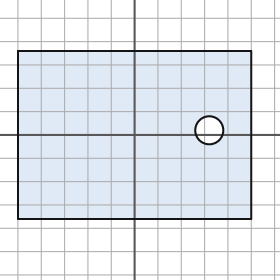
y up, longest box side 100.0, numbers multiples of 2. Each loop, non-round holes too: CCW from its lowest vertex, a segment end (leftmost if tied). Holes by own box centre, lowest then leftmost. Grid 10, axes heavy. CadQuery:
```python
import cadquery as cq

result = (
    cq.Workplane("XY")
    .moveTo(-50.0, -36.0)
    .lineTo(50.0, -36.0)
    .lineTo(50.0, 36.0)
    .lineTo(-50.0, 36.0)
    .close()
    .moveTo(32.0, 2.0)
    .circle(6.0)
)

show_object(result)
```